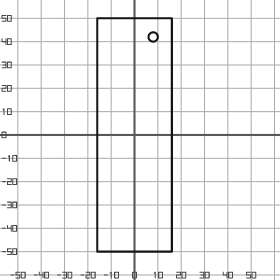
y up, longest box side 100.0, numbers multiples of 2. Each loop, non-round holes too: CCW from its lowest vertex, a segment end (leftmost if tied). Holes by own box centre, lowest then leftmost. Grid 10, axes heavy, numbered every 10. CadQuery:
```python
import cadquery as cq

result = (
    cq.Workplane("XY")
    .moveTo(-16.0, -50.0)
    .lineTo(16.0, -50.0)
    .lineTo(16.0, 50.0)
    .lineTo(-16.0, 50.0)
    .close()
    .moveTo(8.0, 42.0)
    .circle(2.0)
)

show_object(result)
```